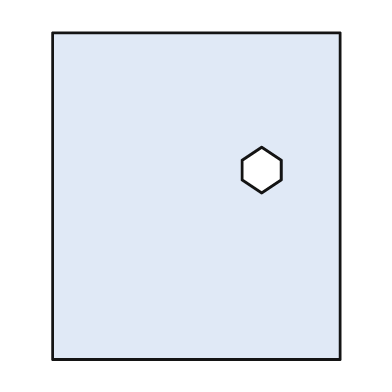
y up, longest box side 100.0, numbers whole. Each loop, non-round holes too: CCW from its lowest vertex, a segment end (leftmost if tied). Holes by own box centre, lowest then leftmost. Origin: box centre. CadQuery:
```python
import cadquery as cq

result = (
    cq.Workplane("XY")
    .moveTo(-44.0, -50.0)
    .lineTo(44.0, -50.0)
    .lineTo(44.0, 50.0)
    .lineTo(-44.0, 50.0)
    .close()
    .moveTo(20.0, 1.0)
    .lineTo(26.0, 5.0)
    .lineTo(26.0, 11.0)
    .lineTo(20.0, 15.0)
    .lineTo(14.0, 11.0)
    .lineTo(14.0, 5.0)
    .close()
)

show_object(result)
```